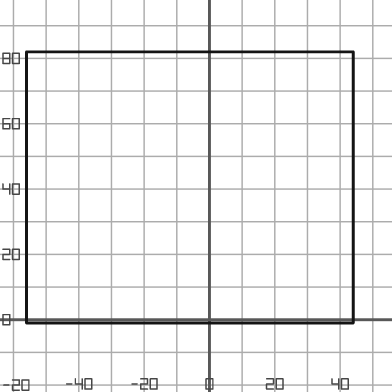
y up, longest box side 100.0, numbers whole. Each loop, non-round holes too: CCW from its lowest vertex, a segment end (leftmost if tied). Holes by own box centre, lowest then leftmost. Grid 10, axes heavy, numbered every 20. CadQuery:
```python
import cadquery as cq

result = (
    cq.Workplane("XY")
    .moveTo(-56.0, -1.0)
    .lineTo(44.0, -1.0)
    .lineTo(44.0, 82.0)
    .lineTo(-56.0, 82.0)
    .close()
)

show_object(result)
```